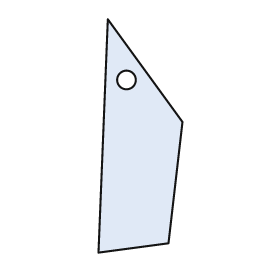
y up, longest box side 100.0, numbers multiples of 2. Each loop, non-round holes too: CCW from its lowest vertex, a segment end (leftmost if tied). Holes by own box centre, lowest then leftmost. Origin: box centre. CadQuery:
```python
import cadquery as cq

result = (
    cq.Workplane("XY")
    .moveTo(-18.0, -50.0)
    .lineTo(12.0, -46.0)
    .lineTo(18.0, 6.0)
    .lineTo(-14.0, 50.0)
    .close()
    .moveTo(-6.0, 24.0)
    .circle(4.0)
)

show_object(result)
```